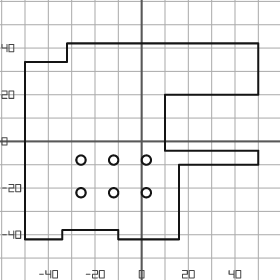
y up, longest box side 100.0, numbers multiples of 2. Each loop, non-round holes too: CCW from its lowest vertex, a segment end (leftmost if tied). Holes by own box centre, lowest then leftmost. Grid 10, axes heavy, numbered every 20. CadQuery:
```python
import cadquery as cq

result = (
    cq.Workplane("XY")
    .moveTo(-50.0, -42.0)
    .lineTo(-34.0, -42.0)
    .lineTo(-34.0, -38.0)
    .lineTo(-10.0, -38.0)
    .lineTo(-10.0, -42.0)
    .lineTo(16.0, -42.0)
    .lineTo(16.0, -10.0)
    .lineTo(50.0, -10.0)
    .lineTo(50.0, -4.0)
    .lineTo(10.0, -4.0)
    .lineTo(10.0, 20.0)
    .lineTo(50.0, 20.0)
    .lineTo(50.0, 42.0)
    .lineTo(-32.0, 42.0)
    .lineTo(-32.0, 34.0)
    .lineTo(-50.0, 34.0)
    .close()
    .moveTo(-26.0, -22.0)
    .circle(2.0)
    .moveTo(-12.0, -22.0)
    .circle(2.0)
    .moveTo(2.0, -22.0)
    .circle(2.0)
    .moveTo(-26.0, -8.0)
    .circle(2.0)
    .moveTo(-12.0, -8.0)
    .circle(2.0)
    .moveTo(2.0, -8.0)
    .circle(2.0)
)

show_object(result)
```